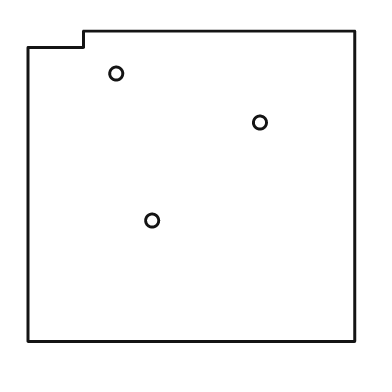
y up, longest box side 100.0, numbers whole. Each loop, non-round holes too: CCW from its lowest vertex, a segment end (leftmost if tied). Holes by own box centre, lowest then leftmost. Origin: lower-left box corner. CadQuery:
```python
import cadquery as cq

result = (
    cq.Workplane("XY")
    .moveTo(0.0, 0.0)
    .lineTo(100.0, 0.0)
    .lineTo(100.0, 95.0)
    .lineTo(17.0, 95.0)
    .lineTo(17.0, 90.0)
    .lineTo(0.0, 90.0)
    .close()
    .moveTo(38.0, 37.0)
    .circle(2.0)
    .moveTo(71.0, 67.0)
    .circle(2.0)
    .moveTo(27.0, 82.0)
    .circle(2.0)
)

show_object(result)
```